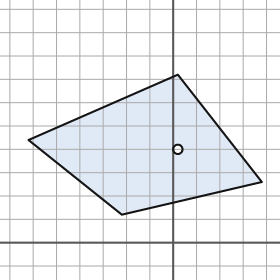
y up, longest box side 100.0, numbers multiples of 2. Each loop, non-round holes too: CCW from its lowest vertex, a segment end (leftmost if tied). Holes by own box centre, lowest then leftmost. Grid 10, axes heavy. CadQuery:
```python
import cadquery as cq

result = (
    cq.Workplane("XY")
    .moveTo(-22.0, 12.0)
    .lineTo(38.0, 26.0)
    .lineTo(2.0, 72.0)
    .lineTo(-62.0, 44.0)
    .close()
    .moveTo(2.0, 40.0)
    .circle(2.0)
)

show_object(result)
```